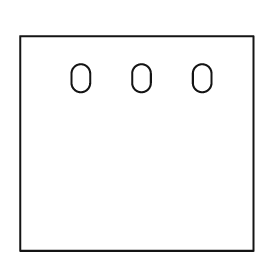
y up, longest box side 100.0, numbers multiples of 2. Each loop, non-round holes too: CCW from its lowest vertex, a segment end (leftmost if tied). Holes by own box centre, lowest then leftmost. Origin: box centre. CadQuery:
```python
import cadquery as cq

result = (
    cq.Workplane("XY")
    .moveTo(-50.0, -46.0)
    .lineTo(50.0, -46.0)
    .lineTo(50.0, 46.0)
    .lineTo(-50.0, 46.0)
    .close()
    .moveTo(-28.0, 26.0)
    .threePointArc((-24.0, 22.0), (-20.0, 26.0))
    .lineTo(-20.0, 30.0)
    .threePointArc((-24.0, 34.0), (-28.0, 30.0))
    .close()
    .moveTo(-2.0, 26.0)
    .threePointArc((2.0, 22.0), (6.0, 26.0))
    .lineTo(6.0, 30.0)
    .threePointArc((2.0, 34.0), (-2.0, 30.0))
    .close()
    .moveTo(24.0, 26.0)
    .threePointArc((28.0, 22.0), (32.0, 26.0))
    .lineTo(32.0, 30.0)
    .threePointArc((28.0, 34.0), (24.0, 30.0))
    .close()
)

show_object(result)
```